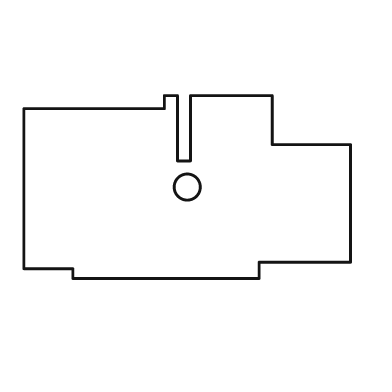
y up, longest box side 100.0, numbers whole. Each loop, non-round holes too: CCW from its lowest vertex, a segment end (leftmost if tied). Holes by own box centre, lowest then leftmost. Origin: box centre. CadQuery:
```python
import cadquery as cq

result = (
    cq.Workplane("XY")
    .moveTo(-35.0, -28.0)
    .lineTo(22.0, -28.0)
    .lineTo(22.0, -23.0)
    .lineTo(50.0, -23.0)
    .lineTo(50.0, 13.0)
    .lineTo(26.0, 13.0)
    .lineTo(26.0, 28.0)
    .lineTo(1.0, 28.0)
    .lineTo(1.0, 8.0)
    .lineTo(-3.0, 8.0)
    .lineTo(-3.0, 28.0)
    .lineTo(-7.0, 28.0)
    .lineTo(-7.0, 24.0)
    .lineTo(-50.0, 24.0)
    .lineTo(-50.0, -25.0)
    .lineTo(-35.0, -25.0)
    .close()
    .moveTo(0.0, 0.0)
    .circle(4.0)
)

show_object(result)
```